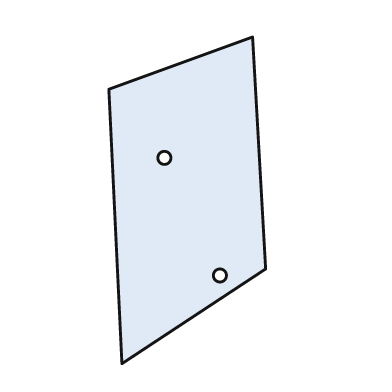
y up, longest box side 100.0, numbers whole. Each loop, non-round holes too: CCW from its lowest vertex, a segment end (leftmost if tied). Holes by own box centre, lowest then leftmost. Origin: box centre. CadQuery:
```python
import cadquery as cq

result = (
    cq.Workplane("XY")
    .moveTo(-20.0, -50.0)
    .lineTo(24.0, -21.0)
    .lineTo(20.0, 50.0)
    .lineTo(-24.0, 34.0)
    .close()
    .moveTo(10.0, -23.0)
    .circle(2.0)
    .moveTo(-7.0, 13.0)
    .circle(2.0)
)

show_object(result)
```